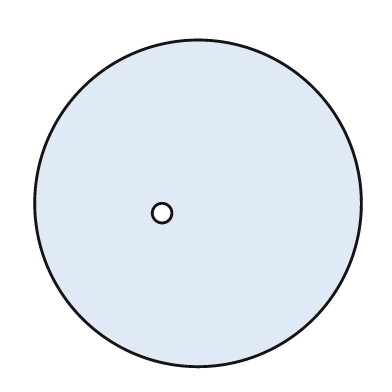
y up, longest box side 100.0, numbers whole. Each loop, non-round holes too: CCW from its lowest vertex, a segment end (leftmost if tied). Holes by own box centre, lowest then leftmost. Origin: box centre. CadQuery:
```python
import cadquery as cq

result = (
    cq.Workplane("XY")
    .moveTo(0.0, 0.0)
    .circle(50.0)
    .moveTo(-11.0, -3.0)
    .circle(3.0)
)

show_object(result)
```